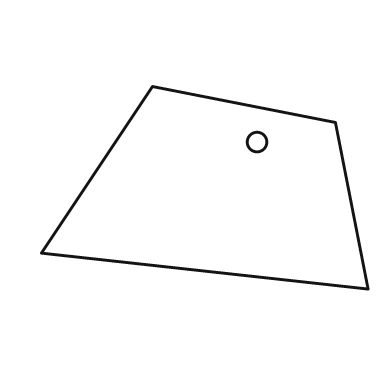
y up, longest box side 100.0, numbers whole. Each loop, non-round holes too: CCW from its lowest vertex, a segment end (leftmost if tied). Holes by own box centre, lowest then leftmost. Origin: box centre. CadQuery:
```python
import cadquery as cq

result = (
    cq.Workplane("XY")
    .moveTo(50.0, -31.0)
    .lineTo(40.0, 20.0)
    .lineTo(-16.0, 31.0)
    .lineTo(-50.0, -20.0)
    .close()
    .moveTo(16.0, 14.0)
    .circle(3.0)
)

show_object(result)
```